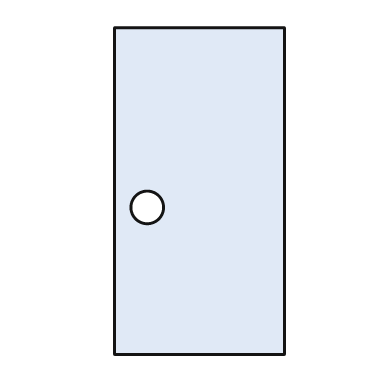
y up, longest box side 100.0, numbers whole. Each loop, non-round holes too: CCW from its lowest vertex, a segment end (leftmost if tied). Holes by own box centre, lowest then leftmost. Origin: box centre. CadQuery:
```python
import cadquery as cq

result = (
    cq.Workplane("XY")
    .moveTo(-26.0, -50.0)
    .lineTo(26.0, -50.0)
    .lineTo(26.0, 50.0)
    .lineTo(-26.0, 50.0)
    .close()
    .moveTo(-16.0, -5.0)
    .circle(5.0)
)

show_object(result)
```